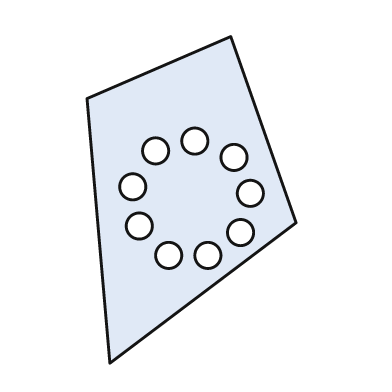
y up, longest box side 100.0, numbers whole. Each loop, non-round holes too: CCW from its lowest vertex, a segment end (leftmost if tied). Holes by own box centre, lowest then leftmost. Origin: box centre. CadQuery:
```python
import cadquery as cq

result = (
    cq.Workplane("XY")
    .moveTo(-25.0, -50.0)
    .lineTo(32.0, -7.0)
    .lineTo(12.0, 50.0)
    .lineTo(-32.0, 31.0)
    .close()
    .moveTo(-7.0, -17.0)
    .circle(4.0)
    .moveTo(5.0, -17.0)
    .circle(4.0)
    .moveTo(15.0, -10.0)
    .circle(4.0)
    .moveTo(-16.0, -8.0)
    .circle(4.0)
    .moveTo(18.0, 2.0)
    .circle(4.0)
    .moveTo(-18.0, 4.0)
    .circle(4.0)
    .moveTo(13.0, 13.0)
    .circle(4.0)
    .moveTo(-11.0, 15.0)
    .circle(4.0)
    .moveTo(1.0, 18.0)
    .circle(4.0)
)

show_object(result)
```